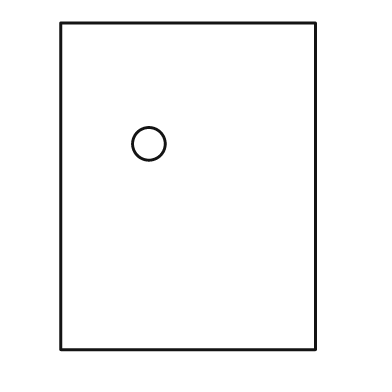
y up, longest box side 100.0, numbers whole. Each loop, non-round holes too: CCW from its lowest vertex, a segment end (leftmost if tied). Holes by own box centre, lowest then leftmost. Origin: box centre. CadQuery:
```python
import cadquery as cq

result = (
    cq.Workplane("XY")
    .moveTo(-39.0, -50.0)
    .lineTo(39.0, -50.0)
    .lineTo(39.0, 50.0)
    .lineTo(-39.0, 50.0)
    .close()
    .moveTo(-12.0, 13.0)
    .circle(5.0)
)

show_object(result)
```